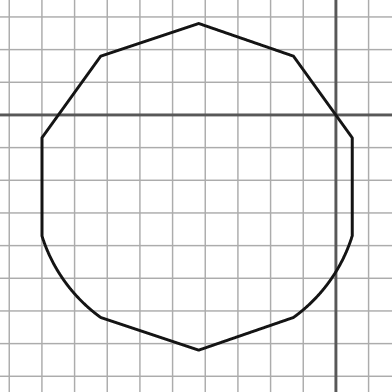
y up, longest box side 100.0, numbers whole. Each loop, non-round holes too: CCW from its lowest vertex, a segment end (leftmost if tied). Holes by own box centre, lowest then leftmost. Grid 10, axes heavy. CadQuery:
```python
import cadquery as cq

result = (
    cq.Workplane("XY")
    .moveTo(-42.0, -72.0)
    .lineTo(-13.0, -62.0)
    .threePointArc((-2.0, -51.0), (5.0, -37.0))
    .lineTo(5.0, -7.0)
    .lineTo(-13.0, 18.0)
    .lineTo(-42.0, 28.0)
    .lineTo(-72.0, 18.0)
    .lineTo(-90.0, -7.0)
    .lineTo(-90.0, -37.0)
    .threePointArc((-83.0, -51.0), (-72.0, -62.0))
    .close()
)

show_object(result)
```